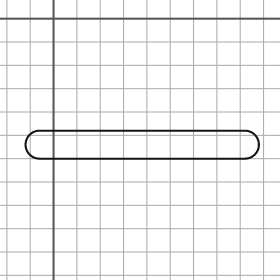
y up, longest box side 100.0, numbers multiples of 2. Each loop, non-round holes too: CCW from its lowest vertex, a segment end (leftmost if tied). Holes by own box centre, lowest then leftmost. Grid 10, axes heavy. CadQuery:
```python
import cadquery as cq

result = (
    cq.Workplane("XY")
    .moveTo(-6.0, -60.0)
    .lineTo(82.0, -60.0)
    .threePointArc((88.0, -54.0), (82.0, -48.0))
    .lineTo(-6.0, -48.0)
    .threePointArc((-12.0, -54.0), (-6.0, -60.0))
    .close()
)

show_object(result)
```